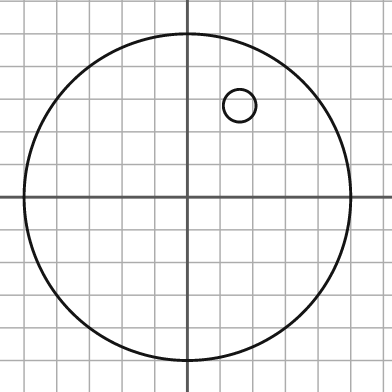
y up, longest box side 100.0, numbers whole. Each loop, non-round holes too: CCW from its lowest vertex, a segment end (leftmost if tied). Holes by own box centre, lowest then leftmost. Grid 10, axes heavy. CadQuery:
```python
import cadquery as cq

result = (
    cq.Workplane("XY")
    .moveTo(0.0, 0.0)
    .circle(50.0)
    .moveTo(16.0, 28.0)
    .circle(5.0)
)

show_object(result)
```